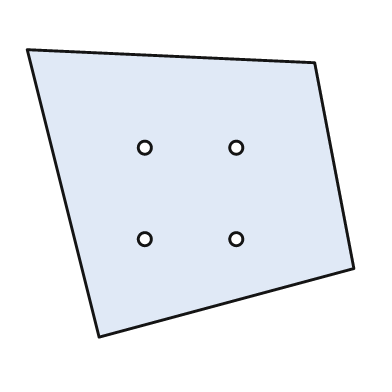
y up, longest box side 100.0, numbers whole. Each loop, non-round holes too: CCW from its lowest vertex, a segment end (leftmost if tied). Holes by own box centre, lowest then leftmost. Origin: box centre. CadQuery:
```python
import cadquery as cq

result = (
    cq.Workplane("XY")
    .moveTo(-28.0, -44.0)
    .lineTo(50.0, -23.0)
    .lineTo(38.0, 40.0)
    .lineTo(-50.0, 44.0)
    .close()
    .moveTo(-14.0, -14.0)
    .circle(2.0)
    .moveTo(14.0, -14.0)
    .circle(2.0)
    .moveTo(-14.0, 14.0)
    .circle(2.0)
    .moveTo(14.0, 14.0)
    .circle(2.0)
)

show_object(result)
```